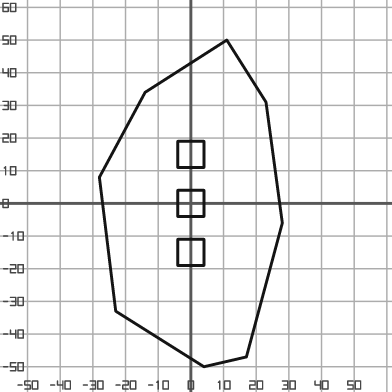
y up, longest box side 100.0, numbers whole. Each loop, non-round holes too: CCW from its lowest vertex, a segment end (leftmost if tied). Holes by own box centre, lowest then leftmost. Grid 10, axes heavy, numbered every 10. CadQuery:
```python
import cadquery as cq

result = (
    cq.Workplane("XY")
    .moveTo(4.0, -50.0)
    .lineTo(17.0, -47.0)
    .lineTo(28.0, -6.0)
    .lineTo(23.0, 31.0)
    .lineTo(11.0, 50.0)
    .lineTo(-14.0, 34.0)
    .lineTo(-28.0, 8.0)
    .lineTo(-23.0, -33.0)
    .close()
    .moveTo(-4.0, -19.0)
    .lineTo(4.0, -19.0)
    .lineTo(4.0, -11.0)
    .lineTo(-4.0, -11.0)
    .close()
    .moveTo(-4.0, -4.0)
    .lineTo(4.0, -4.0)
    .lineTo(4.0, 4.0)
    .lineTo(-4.0, 4.0)
    .close()
    .moveTo(-4.0, 11.0)
    .lineTo(4.0, 11.0)
    .lineTo(4.0, 19.0)
    .lineTo(-4.0, 19.0)
    .close()
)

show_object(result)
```